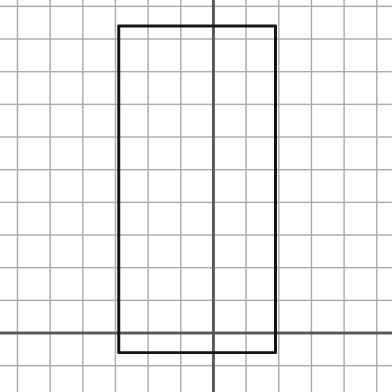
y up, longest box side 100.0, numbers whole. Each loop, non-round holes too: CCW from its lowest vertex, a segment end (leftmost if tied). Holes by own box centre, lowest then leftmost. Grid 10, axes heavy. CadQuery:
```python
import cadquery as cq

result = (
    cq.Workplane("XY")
    .moveTo(-29.0, -6.0)
    .lineTo(19.0, -6.0)
    .lineTo(19.0, 94.0)
    .lineTo(-29.0, 94.0)
    .close()
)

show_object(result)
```